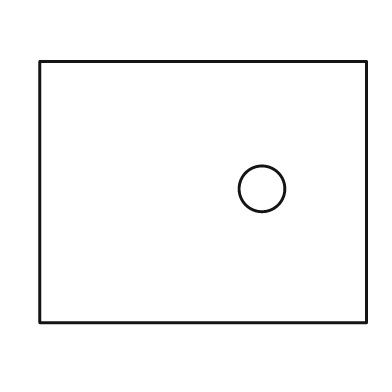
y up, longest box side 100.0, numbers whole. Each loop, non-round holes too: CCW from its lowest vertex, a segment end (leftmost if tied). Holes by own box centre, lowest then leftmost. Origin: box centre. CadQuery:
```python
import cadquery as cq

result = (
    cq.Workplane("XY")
    .moveTo(-50.0, -40.0)
    .lineTo(50.0, -40.0)
    .lineTo(50.0, 40.0)
    .lineTo(-50.0, 40.0)
    .close()
    .moveTo(18.0, 1.0)
    .circle(7.0)
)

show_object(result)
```